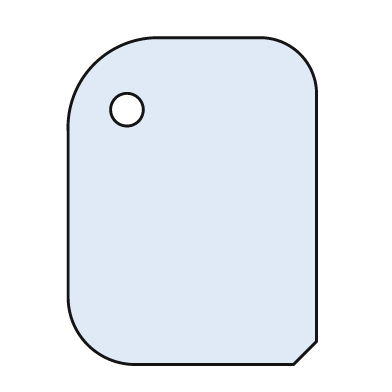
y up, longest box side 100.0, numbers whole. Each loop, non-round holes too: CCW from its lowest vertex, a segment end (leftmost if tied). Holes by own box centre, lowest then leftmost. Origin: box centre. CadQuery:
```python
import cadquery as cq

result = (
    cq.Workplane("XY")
    .moveTo(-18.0, -50.0)
    .lineTo(31.0, -50.0)
    .lineTo(38.0, -43.0)
    .lineTo(38.0, 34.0)
    .threePointArc((33.0, 45.0), (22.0, 50.0))
    .lineTo(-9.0, 50.0)
    .threePointArc((-30.0, 42.0), (-38.0, 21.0))
    .lineTo(-38.0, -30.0)
    .threePointArc((-32.0, -44.0), (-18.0, -50.0))
    .close()
    .moveTo(-20.0, 28.0)
    .circle(5.0)
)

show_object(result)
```